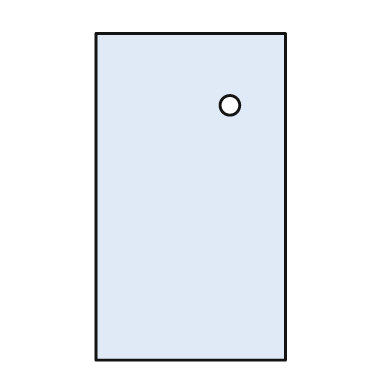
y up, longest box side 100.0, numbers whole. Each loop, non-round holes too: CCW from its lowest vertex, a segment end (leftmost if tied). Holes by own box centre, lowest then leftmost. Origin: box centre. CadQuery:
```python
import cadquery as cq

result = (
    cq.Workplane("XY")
    .moveTo(-29.0, -50.0)
    .lineTo(29.0, -50.0)
    .lineTo(29.0, 50.0)
    .lineTo(-29.0, 50.0)
    .close()
    .moveTo(12.0, 28.0)
    .circle(3.0)
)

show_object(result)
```